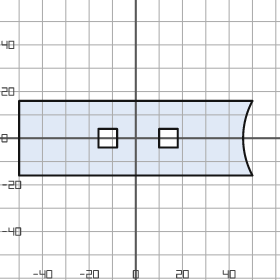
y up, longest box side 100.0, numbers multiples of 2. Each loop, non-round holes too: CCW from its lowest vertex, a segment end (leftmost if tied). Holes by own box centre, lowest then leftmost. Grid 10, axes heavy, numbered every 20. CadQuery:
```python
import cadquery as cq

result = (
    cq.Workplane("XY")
    .moveTo(-50.0, -16.0)
    .lineTo(50.0, -16.0)
    .threePointArc((46.0, 0.0), (50.0, 16.0))
    .lineTo(-50.0, 16.0)
    .close()
    .moveTo(-16.0, -4.0)
    .lineTo(-8.0, -4.0)
    .lineTo(-8.0, 4.0)
    .lineTo(-16.0, 4.0)
    .close()
    .moveTo(10.0, -4.0)
    .lineTo(18.0, -4.0)
    .lineTo(18.0, 4.0)
    .lineTo(10.0, 4.0)
    .close()
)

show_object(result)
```